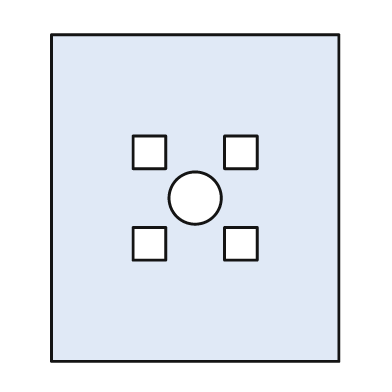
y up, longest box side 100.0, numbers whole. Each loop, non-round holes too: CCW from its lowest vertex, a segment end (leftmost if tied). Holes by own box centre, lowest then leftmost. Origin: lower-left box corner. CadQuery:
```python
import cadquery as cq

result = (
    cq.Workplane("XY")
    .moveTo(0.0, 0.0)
    .lineTo(88.0, 0.0)
    .lineTo(88.0, 100.0)
    .lineTo(0.0, 100.0)
    .close()
    .moveTo(25.0, 31.0)
    .lineTo(35.0, 31.0)
    .lineTo(35.0, 41.0)
    .lineTo(25.0, 41.0)
    .close()
    .moveTo(53.0, 31.0)
    .lineTo(63.0, 31.0)
    .lineTo(63.0, 41.0)
    .lineTo(53.0, 41.0)
    .close()
    .moveTo(44.0, 50.0)
    .circle(8.0)
    .moveTo(25.0, 59.0)
    .lineTo(35.0, 59.0)
    .lineTo(35.0, 69.0)
    .lineTo(25.0, 69.0)
    .close()
    .moveTo(53.0, 59.0)
    .lineTo(63.0, 59.0)
    .lineTo(63.0, 69.0)
    .lineTo(53.0, 69.0)
    .close()
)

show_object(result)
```